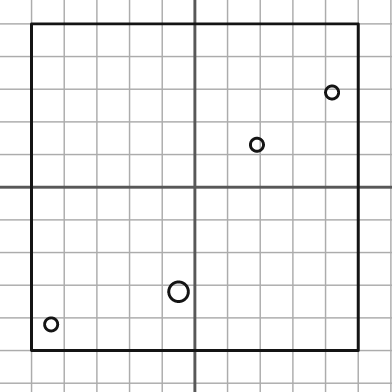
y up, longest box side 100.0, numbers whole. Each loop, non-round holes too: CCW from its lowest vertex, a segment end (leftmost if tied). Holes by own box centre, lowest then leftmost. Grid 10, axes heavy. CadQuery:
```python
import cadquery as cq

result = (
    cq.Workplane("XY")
    .moveTo(-50.0, -50.0)
    .lineTo(50.0, -50.0)
    .lineTo(50.0, 50.0)
    .lineTo(-50.0, 50.0)
    .close()
    .moveTo(-44.0, -42.0)
    .circle(2.0)
    .moveTo(-5.0, -32.0)
    .circle(3.0)
    .moveTo(19.0, 13.0)
    .circle(2.0)
    .moveTo(42.0, 29.0)
    .circle(2.0)
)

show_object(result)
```